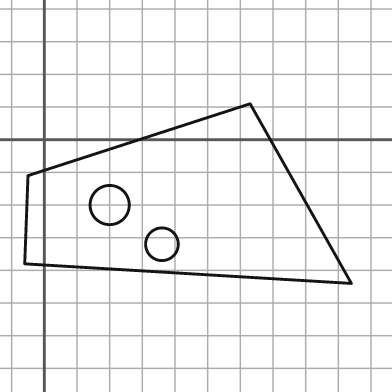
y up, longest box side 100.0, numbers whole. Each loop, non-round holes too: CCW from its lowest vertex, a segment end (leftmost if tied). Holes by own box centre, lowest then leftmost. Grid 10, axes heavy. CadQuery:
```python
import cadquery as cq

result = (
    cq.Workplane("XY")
    .moveTo(94.0, -44.0)
    .lineTo(63.0, 11.0)
    .lineTo(-5.0, -11.0)
    .lineTo(-6.0, -38.0)
    .close()
    .moveTo(36.0, -32.0)
    .circle(5.0)
    .moveTo(20.0, -20.0)
    .circle(6.0)
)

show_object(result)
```